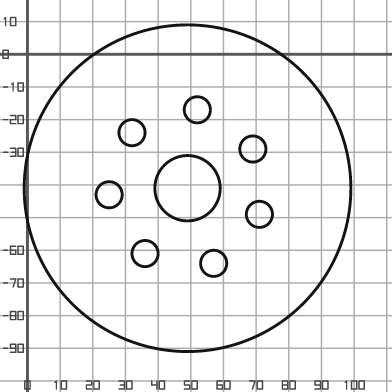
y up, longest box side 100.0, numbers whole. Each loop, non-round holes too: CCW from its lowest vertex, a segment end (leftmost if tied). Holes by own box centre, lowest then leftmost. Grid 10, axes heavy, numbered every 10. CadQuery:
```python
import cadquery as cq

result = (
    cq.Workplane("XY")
    .moveTo(49.0, -41.0)
    .circle(50.0)
    .moveTo(57.0, -64.0)
    .circle(4.0)
    .moveTo(36.0, -61.0)
    .circle(4.0)
    .moveTo(71.0, -49.0)
    .circle(4.0)
    .moveTo(25.0, -43.0)
    .circle(4.0)
    .moveTo(49.0, -41.0)
    .circle(10.0)
    .moveTo(69.0, -29.0)
    .circle(4.0)
    .moveTo(32.0, -24.0)
    .circle(4.0)
    .moveTo(52.0, -17.0)
    .circle(4.0)
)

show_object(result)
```